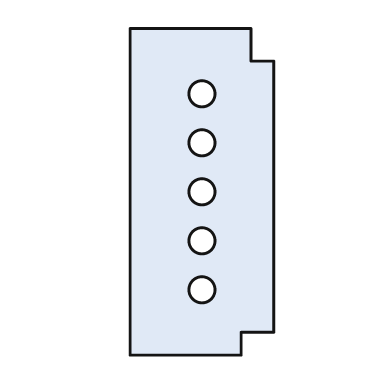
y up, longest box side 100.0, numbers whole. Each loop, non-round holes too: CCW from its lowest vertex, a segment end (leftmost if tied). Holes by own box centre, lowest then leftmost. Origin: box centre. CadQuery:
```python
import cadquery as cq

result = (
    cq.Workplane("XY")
    .moveTo(-22.0, -50.0)
    .lineTo(12.0, -50.0)
    .lineTo(12.0, -43.0)
    .lineTo(22.0, -43.0)
    .lineTo(22.0, 40.0)
    .lineTo(15.0, 40.0)
    .lineTo(15.0, 50.0)
    .lineTo(-22.0, 50.0)
    .close()
    .moveTo(0.0, -30.0)
    .circle(4.0)
    .moveTo(0.0, -15.0)
    .circle(4.0)
    .moveTo(0.0, 0.0)
    .circle(4.0)
    .moveTo(0.0, 15.0)
    .circle(4.0)
    .moveTo(0.0, 30.0)
    .circle(4.0)
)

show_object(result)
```